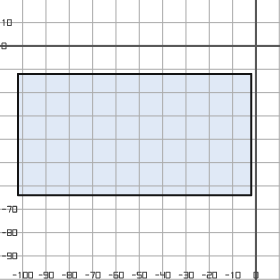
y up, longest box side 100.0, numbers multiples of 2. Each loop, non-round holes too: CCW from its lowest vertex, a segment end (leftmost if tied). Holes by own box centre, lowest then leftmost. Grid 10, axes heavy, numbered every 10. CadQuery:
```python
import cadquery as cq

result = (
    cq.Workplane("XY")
    .moveTo(-102.0, -64.0)
    .lineTo(-2.0, -64.0)
    .lineTo(-2.0, -12.0)
    .lineTo(-102.0, -12.0)
    .close()
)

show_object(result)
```